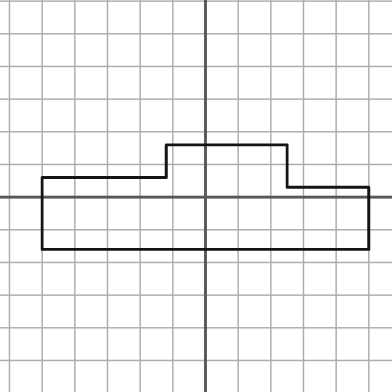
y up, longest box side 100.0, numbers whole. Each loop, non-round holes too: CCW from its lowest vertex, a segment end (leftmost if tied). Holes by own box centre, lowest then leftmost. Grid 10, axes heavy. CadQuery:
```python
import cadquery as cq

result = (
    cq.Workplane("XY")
    .moveTo(-50.0, -16.0)
    .lineTo(50.0, -16.0)
    .lineTo(50.0, 3.0)
    .lineTo(25.0, 3.0)
    .lineTo(25.0, 16.0)
    .lineTo(-12.0, 16.0)
    .lineTo(-12.0, 6.0)
    .lineTo(-50.0, 6.0)
    .close()
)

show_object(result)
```